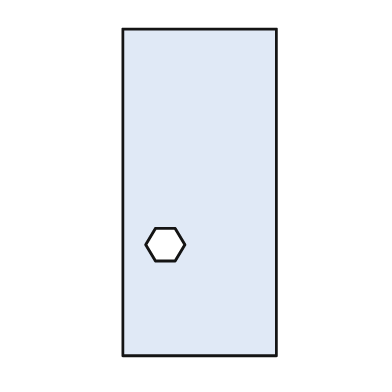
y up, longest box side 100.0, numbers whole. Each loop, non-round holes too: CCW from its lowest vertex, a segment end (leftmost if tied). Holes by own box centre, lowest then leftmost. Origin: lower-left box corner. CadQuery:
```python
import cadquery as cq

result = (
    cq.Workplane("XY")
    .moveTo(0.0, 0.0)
    .lineTo(47.0, 0.0)
    .lineTo(47.0, 100.0)
    .lineTo(0.0, 100.0)
    .close()
    .moveTo(10.0, 29.0)
    .lineTo(16.0, 29.0)
    .lineTo(19.0, 34.0)
    .lineTo(16.0, 39.0)
    .lineTo(10.0, 39.0)
    .lineTo(7.0, 34.0)
    .close()
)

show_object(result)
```